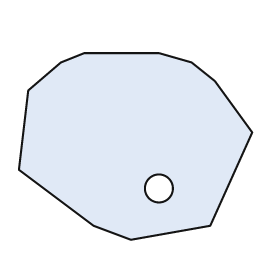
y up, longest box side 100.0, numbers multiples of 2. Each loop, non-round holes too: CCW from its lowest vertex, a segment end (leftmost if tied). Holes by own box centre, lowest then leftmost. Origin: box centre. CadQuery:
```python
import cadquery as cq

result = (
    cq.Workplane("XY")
    .moveTo(-2.0, -40.0)
    .lineTo(32.0, -34.0)
    .lineTo(50.0, 6.0)
    .lineTo(34.0, 28.0)
    .lineTo(24.0, 36.0)
    .lineTo(10.0, 40.0)
    .lineTo(-22.0, 40.0)
    .lineTo(-32.0, 36.0)
    .lineTo(-46.0, 24.0)
    .lineTo(-50.0, -10.0)
    .lineTo(-18.0, -34.0)
    .close()
    .moveTo(10.0, -18.0)
    .circle(6.0)
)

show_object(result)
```